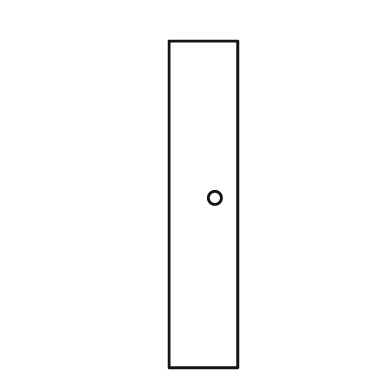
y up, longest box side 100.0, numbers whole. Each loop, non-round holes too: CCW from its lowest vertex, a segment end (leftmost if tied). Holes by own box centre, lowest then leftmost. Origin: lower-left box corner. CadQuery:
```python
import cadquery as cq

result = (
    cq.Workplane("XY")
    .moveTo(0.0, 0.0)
    .lineTo(21.0, 0.0)
    .lineTo(21.0, 100.0)
    .lineTo(0.0, 100.0)
    .close()
    .moveTo(14.0, 52.0)
    .circle(2.0)
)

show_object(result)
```